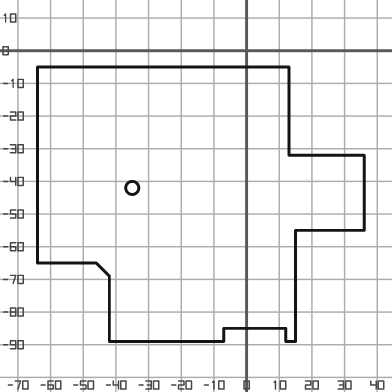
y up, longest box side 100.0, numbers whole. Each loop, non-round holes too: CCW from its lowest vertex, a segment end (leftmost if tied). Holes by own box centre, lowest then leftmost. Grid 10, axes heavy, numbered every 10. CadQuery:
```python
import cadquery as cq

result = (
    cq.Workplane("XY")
    .moveTo(-42.0, -89.0)
    .lineTo(-7.0, -89.0)
    .lineTo(-7.0, -85.0)
    .lineTo(12.0, -85.0)
    .lineTo(12.0, -89.0)
    .lineTo(15.0, -89.0)
    .lineTo(15.0, -55.0)
    .lineTo(36.0, -55.0)
    .lineTo(36.0, -32.0)
    .lineTo(13.0, -32.0)
    .lineTo(13.0, -5.0)
    .lineTo(-64.0, -5.0)
    .lineTo(-64.0, -65.0)
    .lineTo(-46.0, -65.0)
    .lineTo(-42.0, -69.0)
    .close()
    .moveTo(-35.0, -42.0)
    .circle(2.0)
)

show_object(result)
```